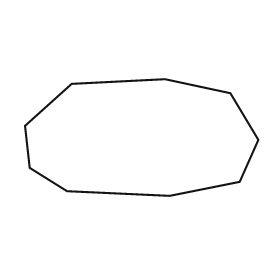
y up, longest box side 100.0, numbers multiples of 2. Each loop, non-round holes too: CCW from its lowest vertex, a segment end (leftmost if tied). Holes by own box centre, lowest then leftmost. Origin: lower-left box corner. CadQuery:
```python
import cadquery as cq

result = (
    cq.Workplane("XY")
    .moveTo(62.0, 0.0)
    .lineTo(92.0, 6.0)
    .lineTo(100.0, 24.0)
    .lineTo(88.0, 44.0)
    .lineTo(60.0, 50.0)
    .lineTo(20.0, 48.0)
    .lineTo(0.0, 30.0)
    .lineTo(2.0, 12.0)
    .lineTo(18.0, 2.0)
    .close()
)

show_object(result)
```